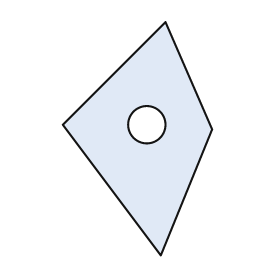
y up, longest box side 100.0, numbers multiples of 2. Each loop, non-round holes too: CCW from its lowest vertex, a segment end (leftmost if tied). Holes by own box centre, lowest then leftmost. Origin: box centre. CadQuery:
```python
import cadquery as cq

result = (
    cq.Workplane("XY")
    .moveTo(10.0, -50.0)
    .lineTo(32.0, 4.0)
    .lineTo(12.0, 50.0)
    .lineTo(-32.0, 6.0)
    .close()
    .moveTo(4.0, 6.0)
    .circle(8.0)
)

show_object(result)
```